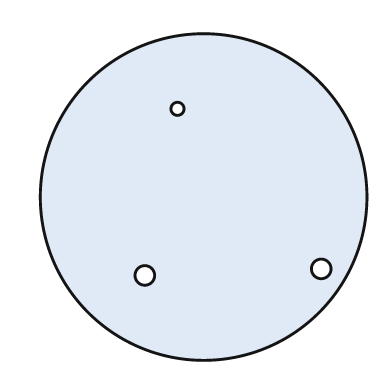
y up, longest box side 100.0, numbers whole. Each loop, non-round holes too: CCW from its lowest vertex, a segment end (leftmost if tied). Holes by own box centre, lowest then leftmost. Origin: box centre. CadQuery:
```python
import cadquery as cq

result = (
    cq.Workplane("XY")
    .moveTo(0.0, 0.0)
    .circle(50.0)
    .moveTo(-18.0, -24.0)
    .circle(3.0)
    .moveTo(36.0, -22.0)
    .circle(3.0)
    .moveTo(-8.0, 27.0)
    .circle(2.0)
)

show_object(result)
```